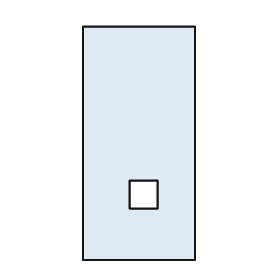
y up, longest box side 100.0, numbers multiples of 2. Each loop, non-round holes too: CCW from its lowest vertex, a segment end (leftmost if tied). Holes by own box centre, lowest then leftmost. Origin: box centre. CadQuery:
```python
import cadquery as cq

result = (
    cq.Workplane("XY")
    .moveTo(-24.0, -50.0)
    .lineTo(24.0, -50.0)
    .lineTo(24.0, 50.0)
    .lineTo(-24.0, 50.0)
    .close()
    .moveTo(-4.0, -28.0)
    .lineTo(8.0, -28.0)
    .lineTo(8.0, -16.0)
    .lineTo(-4.0, -16.0)
    .close()
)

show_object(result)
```